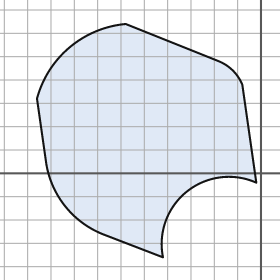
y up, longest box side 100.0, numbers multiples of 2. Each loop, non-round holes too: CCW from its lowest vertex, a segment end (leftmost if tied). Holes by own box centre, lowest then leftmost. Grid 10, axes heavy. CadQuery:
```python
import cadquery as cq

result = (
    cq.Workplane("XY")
    .moveTo(-42.0, -36.0)
    .threePointArc((-32.0, -8.0), (-2.0, -4.0))
    .lineTo(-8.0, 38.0)
    .threePointArc((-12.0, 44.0), (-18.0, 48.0))
    .lineTo(-58.0, 64.0)
    .threePointArc((-82.0, 54.0), (-96.0, 32.0))
    .lineTo(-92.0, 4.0)
    .threePointArc((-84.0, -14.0), (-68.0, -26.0))
    .close()
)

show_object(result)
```